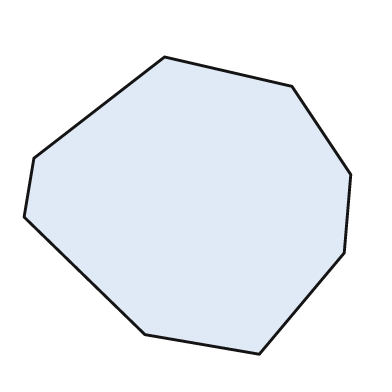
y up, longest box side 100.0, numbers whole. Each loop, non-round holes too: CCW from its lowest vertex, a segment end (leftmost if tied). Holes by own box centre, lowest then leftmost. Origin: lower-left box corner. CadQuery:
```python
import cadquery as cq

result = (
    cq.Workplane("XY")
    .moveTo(72.0, 0.0)
    .lineTo(98.0, 31.0)
    .lineTo(100.0, 55.0)
    .lineTo(82.0, 82.0)
    .lineTo(43.0, 91.0)
    .lineTo(3.0, 60.0)
    .lineTo(0.0, 42.0)
    .lineTo(37.0, 6.0)
    .close()
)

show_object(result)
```